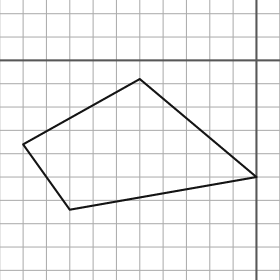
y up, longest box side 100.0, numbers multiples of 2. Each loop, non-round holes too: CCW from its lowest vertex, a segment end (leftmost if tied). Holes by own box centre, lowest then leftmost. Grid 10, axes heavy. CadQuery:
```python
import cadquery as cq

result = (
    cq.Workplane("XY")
    .moveTo(-80.0, -64.0)
    .lineTo(0.0, -50.0)
    .lineTo(-50.0, -8.0)
    .lineTo(-100.0, -36.0)
    .close()
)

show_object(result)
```